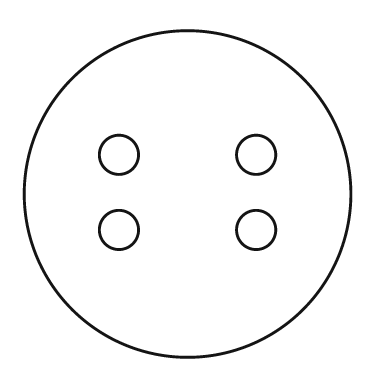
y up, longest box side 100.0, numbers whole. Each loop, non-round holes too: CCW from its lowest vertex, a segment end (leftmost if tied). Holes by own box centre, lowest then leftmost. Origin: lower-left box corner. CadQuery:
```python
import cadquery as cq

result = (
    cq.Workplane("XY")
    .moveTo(50.0, 50.0)
    .circle(50.0)
    .moveTo(29.0, 39.0)
    .circle(6.0)
    .moveTo(71.0, 39.0)
    .circle(6.0)
    .moveTo(29.0, 62.0)
    .circle(6.0)
    .moveTo(71.0, 62.0)
    .circle(6.0)
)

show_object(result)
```